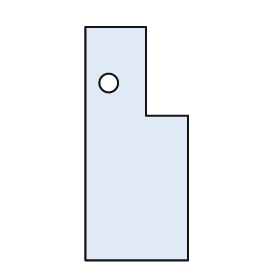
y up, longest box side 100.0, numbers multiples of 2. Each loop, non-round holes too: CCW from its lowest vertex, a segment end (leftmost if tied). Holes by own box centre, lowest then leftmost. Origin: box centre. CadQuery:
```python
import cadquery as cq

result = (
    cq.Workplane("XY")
    .moveTo(-22.0, -50.0)
    .lineTo(22.0, -50.0)
    .lineTo(22.0, 12.0)
    .lineTo(4.0, 12.0)
    .lineTo(4.0, 50.0)
    .lineTo(-22.0, 50.0)
    .close()
    .moveTo(-12.0, 26.0)
    .circle(4.0)
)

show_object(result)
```